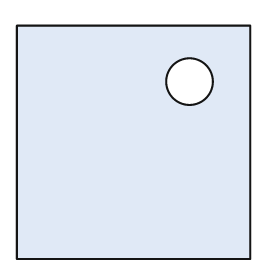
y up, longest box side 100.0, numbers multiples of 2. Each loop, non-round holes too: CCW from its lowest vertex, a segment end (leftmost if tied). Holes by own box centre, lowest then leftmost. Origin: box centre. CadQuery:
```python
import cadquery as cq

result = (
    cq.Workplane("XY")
    .moveTo(-50.0, -50.0)
    .lineTo(50.0, -50.0)
    .lineTo(50.0, 50.0)
    .lineTo(-50.0, 50.0)
    .close()
    .moveTo(24.0, 26.0)
    .circle(10.0)
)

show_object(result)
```